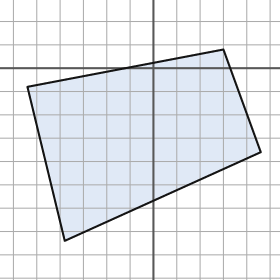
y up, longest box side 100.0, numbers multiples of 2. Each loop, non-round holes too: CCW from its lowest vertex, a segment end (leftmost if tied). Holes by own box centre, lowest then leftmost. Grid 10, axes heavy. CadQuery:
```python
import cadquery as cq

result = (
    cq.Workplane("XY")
    .moveTo(-38.0, -74.0)
    .lineTo(46.0, -36.0)
    .lineTo(30.0, 8.0)
    .lineTo(-54.0, -8.0)
    .close()
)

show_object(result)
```